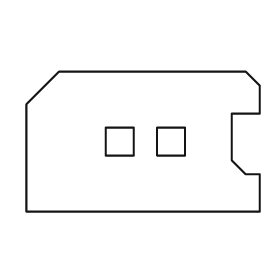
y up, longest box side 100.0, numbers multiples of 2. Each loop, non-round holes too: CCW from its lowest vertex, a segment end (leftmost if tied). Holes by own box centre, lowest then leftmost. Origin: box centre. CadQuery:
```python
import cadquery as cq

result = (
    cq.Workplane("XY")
    .moveTo(-50.0, -30.0)
    .lineTo(50.0, -30.0)
    .lineTo(50.0, -14.0)
    .lineTo(44.0, -14.0)
    .lineTo(38.0, -8.0)
    .lineTo(38.0, 12.0)
    .lineTo(50.0, 12.0)
    .lineTo(50.0, 24.0)
    .lineTo(44.0, 30.0)
    .lineTo(-36.0, 30.0)
    .lineTo(-50.0, 16.0)
    .close()
    .moveTo(-16.0, -6.0)
    .lineTo(-4.0, -6.0)
    .lineTo(-4.0, 6.0)
    .lineTo(-16.0, 6.0)
    .close()
    .moveTo(6.0, -6.0)
    .lineTo(18.0, -6.0)
    .lineTo(18.0, 6.0)
    .lineTo(6.0, 6.0)
    .close()
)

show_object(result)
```